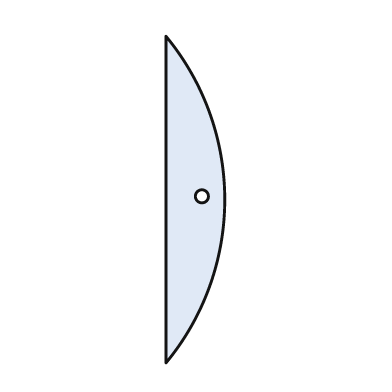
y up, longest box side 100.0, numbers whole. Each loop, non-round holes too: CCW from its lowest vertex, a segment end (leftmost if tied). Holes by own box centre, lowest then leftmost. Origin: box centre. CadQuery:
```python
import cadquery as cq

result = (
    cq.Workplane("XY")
    .moveTo(-9.0, -50.0)
    .threePointArc((9.0, 0.0), (-9.0, 50.0))
    .close()
    .moveTo(2.0, 1.0)
    .circle(2.0)
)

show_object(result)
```